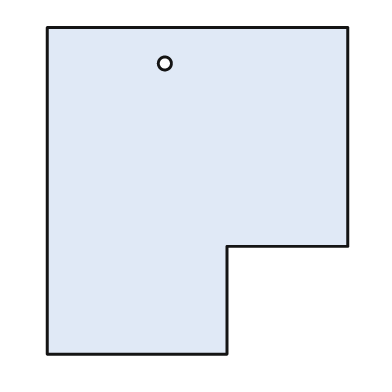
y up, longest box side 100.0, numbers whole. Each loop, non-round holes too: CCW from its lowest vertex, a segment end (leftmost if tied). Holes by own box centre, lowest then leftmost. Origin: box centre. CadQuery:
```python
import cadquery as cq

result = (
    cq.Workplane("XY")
    .moveTo(-46.0, -50.0)
    .lineTo(9.0, -50.0)
    .lineTo(9.0, -17.0)
    .lineTo(46.0, -17.0)
    .lineTo(46.0, 50.0)
    .lineTo(-46.0, 50.0)
    .close()
    .moveTo(-10.0, 39.0)
    .circle(2.0)
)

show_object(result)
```